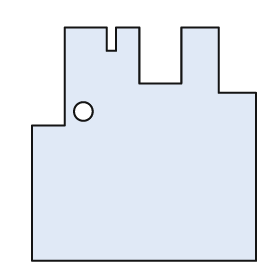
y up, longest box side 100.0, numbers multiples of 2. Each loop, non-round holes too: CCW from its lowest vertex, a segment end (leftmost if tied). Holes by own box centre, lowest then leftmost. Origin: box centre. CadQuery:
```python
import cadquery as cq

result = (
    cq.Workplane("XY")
    .moveTo(-48.0, -50.0)
    .lineTo(48.0, -50.0)
    .lineTo(48.0, 22.0)
    .lineTo(32.0, 22.0)
    .lineTo(32.0, 50.0)
    .lineTo(16.0, 50.0)
    .lineTo(16.0, 26.0)
    .lineTo(-2.0, 26.0)
    .lineTo(-2.0, 50.0)
    .lineTo(-12.0, 50.0)
    .lineTo(-12.0, 40.0)
    .lineTo(-16.0, 40.0)
    .lineTo(-16.0, 50.0)
    .lineTo(-34.0, 50.0)
    .lineTo(-34.0, 8.0)
    .lineTo(-48.0, 8.0)
    .close()
    .moveTo(-26.0, 14.0)
    .circle(4.0)
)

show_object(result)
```